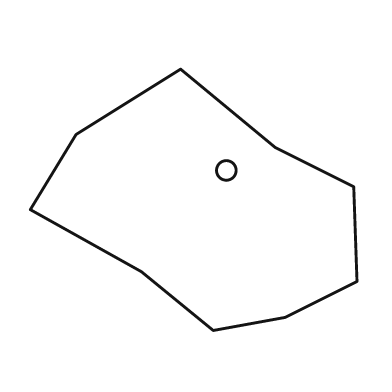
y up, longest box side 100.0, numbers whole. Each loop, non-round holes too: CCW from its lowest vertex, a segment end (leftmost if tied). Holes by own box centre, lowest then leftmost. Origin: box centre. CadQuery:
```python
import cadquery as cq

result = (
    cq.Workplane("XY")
    .moveTo(6.0, -40.0)
    .lineTo(28.0, -36.0)
    .lineTo(50.0, -25.0)
    .lineTo(49.0, 4.0)
    .lineTo(25.0, 16.0)
    .lineTo(-4.0, 40.0)
    .lineTo(-36.0, 20.0)
    .lineTo(-50.0, -3.0)
    .lineTo(-16.0, -22.0)
    .close()
    .moveTo(10.0, 9.0)
    .circle(3.0)
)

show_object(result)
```